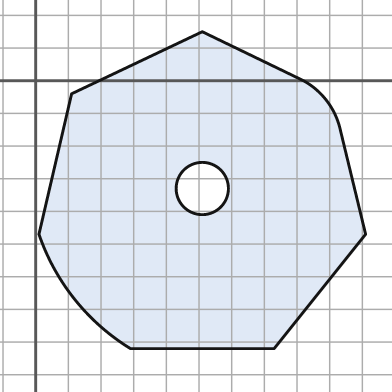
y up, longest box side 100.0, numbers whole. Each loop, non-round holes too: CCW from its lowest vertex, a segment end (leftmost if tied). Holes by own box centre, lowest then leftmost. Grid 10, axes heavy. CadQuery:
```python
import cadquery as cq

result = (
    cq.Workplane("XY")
    .moveTo(29.0, -82.0)
    .lineTo(73.0, -82.0)
    .lineTo(101.0, -47.0)
    .lineTo(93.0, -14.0)
    .threePointArc((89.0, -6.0), (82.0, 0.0))
    .lineTo(51.0, 15.0)
    .lineTo(11.0, -4.0)
    .lineTo(1.0, -47.0)
    .threePointArc((12.0, -67.0), (29.0, -82.0))
    .close()
    .moveTo(51.0, -33.0)
    .circle(8.0)
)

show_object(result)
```